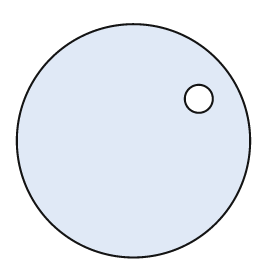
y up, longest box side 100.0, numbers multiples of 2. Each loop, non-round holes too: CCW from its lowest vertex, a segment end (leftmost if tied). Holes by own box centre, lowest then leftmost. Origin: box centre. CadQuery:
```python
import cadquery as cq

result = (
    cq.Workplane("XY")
    .moveTo(0.0, 0.0)
    .circle(50.0)
    .moveTo(28.0, 18.0)
    .circle(6.0)
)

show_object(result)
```